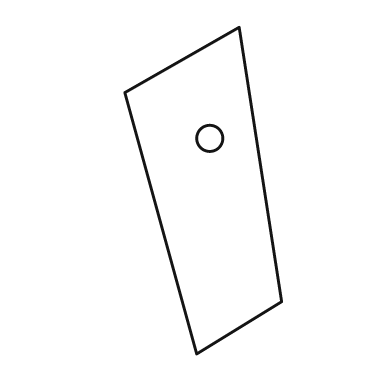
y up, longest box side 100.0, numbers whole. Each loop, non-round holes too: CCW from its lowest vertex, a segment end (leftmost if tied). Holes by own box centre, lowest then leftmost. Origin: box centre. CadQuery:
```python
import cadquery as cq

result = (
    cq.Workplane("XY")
    .moveTo(-2.0, -50.0)
    .lineTo(24.0, -34.0)
    .lineTo(11.0, 50.0)
    .lineTo(-24.0, 30.0)
    .close()
    .moveTo(2.0, 16.0)
    .circle(4.0)
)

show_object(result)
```